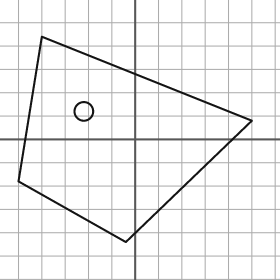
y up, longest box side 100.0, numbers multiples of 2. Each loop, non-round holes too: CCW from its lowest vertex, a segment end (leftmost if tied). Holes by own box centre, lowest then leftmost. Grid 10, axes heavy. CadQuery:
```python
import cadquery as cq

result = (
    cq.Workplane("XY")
    .moveTo(-4.0, -44.0)
    .lineTo(50.0, 8.0)
    .lineTo(-40.0, 44.0)
    .lineTo(-50.0, -18.0)
    .close()
    .moveTo(-22.0, 12.0)
    .circle(4.0)
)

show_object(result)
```